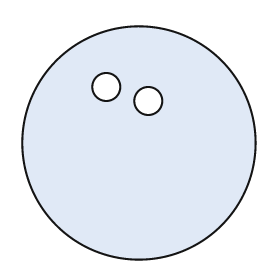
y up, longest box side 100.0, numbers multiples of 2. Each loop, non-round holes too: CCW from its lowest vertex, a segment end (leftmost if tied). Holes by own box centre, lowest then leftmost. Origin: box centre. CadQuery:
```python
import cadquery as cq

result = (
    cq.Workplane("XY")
    .moveTo(0.0, 0.0)
    .circle(50.0)
    .moveTo(4.0, 18.0)
    .circle(6.0)
    .moveTo(-14.0, 24.0)
    .circle(6.0)
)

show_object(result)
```